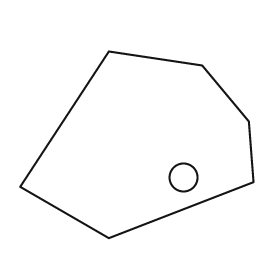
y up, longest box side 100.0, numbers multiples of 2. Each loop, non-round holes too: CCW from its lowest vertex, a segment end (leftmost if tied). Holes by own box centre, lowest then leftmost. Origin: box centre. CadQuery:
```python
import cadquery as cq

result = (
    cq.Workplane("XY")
    .moveTo(-12.0, -40.0)
    .lineTo(50.0, -16.0)
    .lineTo(48.0, 10.0)
    .lineTo(28.0, 34.0)
    .lineTo(-12.0, 40.0)
    .lineTo(-50.0, -18.0)
    .close()
    .moveTo(20.0, -14.0)
    .circle(6.0)
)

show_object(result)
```